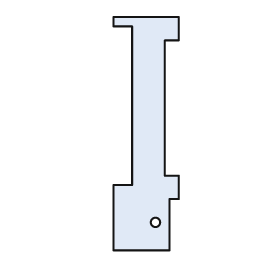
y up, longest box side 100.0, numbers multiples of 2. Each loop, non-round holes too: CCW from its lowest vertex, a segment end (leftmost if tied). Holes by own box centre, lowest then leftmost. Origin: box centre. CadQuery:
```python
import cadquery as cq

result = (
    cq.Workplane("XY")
    .moveTo(-14.0, -50.0)
    .lineTo(10.0, -50.0)
    .lineTo(10.0, -28.0)
    .lineTo(14.0, -28.0)
    .lineTo(14.0, -18.0)
    .lineTo(8.0, -18.0)
    .lineTo(8.0, 40.0)
    .lineTo(14.0, 40.0)
    .lineTo(14.0, 50.0)
    .lineTo(-14.0, 50.0)
    .lineTo(-14.0, 46.0)
    .lineTo(-6.0, 46.0)
    .lineTo(-6.0, -22.0)
    .lineTo(-14.0, -22.0)
    .close()
    .moveTo(4.0, -38.0)
    .circle(2.0)
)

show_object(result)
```